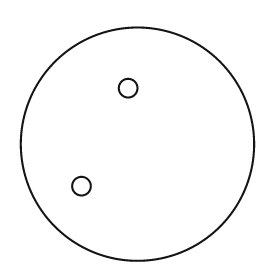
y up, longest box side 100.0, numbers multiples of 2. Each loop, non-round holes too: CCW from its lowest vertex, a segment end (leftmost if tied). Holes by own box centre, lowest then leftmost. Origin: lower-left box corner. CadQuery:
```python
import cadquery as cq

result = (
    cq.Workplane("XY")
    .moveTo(50.0, 50.0)
    .circle(50.0)
    .moveTo(26.0, 32.0)
    .circle(4.0)
    .moveTo(46.0, 74.0)
    .circle(4.0)
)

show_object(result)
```